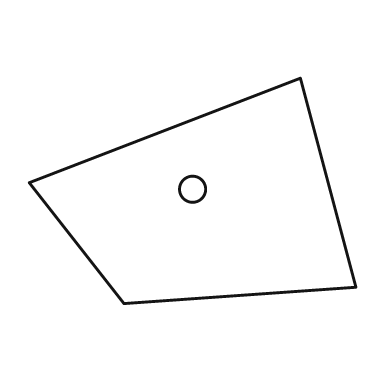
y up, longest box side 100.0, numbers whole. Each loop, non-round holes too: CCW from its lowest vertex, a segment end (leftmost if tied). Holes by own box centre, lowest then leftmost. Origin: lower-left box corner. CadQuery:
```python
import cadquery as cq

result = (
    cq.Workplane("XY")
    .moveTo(29.0, 0.0)
    .lineTo(100.0, 5.0)
    .lineTo(83.0, 69.0)
    .lineTo(0.0, 37.0)
    .close()
    .moveTo(50.0, 35.0)
    .circle(4.0)
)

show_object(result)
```